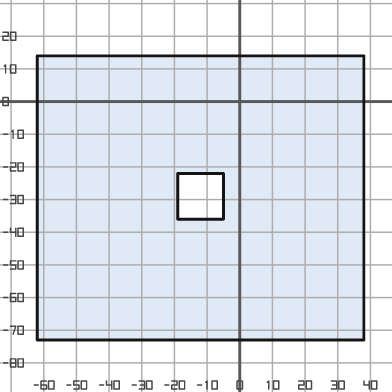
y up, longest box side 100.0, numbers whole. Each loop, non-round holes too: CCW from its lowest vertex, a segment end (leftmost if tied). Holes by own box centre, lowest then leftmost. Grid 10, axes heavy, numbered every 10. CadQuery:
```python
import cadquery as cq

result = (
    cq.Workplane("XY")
    .moveTo(-62.0, -73.0)
    .lineTo(38.0, -73.0)
    .lineTo(38.0, 14.0)
    .lineTo(-62.0, 14.0)
    .close()
    .moveTo(-19.0, -36.0)
    .lineTo(-5.0, -36.0)
    .lineTo(-5.0, -22.0)
    .lineTo(-19.0, -22.0)
    .close()
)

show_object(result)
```